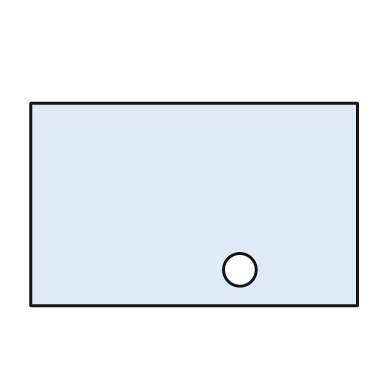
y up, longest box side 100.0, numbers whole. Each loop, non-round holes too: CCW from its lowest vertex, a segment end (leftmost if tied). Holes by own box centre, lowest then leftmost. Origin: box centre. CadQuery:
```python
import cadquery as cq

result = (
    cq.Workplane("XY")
    .moveTo(-50.0, -31.0)
    .lineTo(50.0, -31.0)
    .lineTo(50.0, 31.0)
    .lineTo(-50.0, 31.0)
    .close()
    .moveTo(14.0, -20.0)
    .circle(5.0)
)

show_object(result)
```